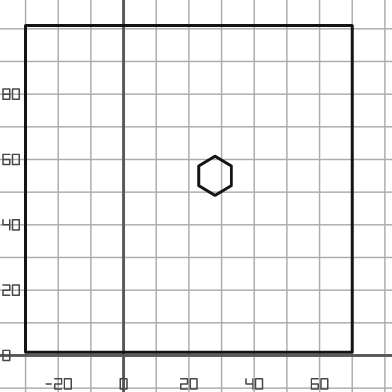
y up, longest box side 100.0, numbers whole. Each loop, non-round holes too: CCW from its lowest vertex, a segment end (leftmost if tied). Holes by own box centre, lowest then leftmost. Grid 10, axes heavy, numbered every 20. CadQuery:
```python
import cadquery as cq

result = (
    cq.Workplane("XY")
    .moveTo(-30.0, 1.0)
    .lineTo(70.0, 1.0)
    .lineTo(70.0, 101.0)
    .lineTo(-30.0, 101.0)
    .close()
    .moveTo(28.0, 49.0)
    .lineTo(33.0, 52.0)
    .lineTo(33.0, 58.0)
    .lineTo(28.0, 61.0)
    .lineTo(23.0, 58.0)
    .lineTo(23.0, 52.0)
    .close()
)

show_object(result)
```